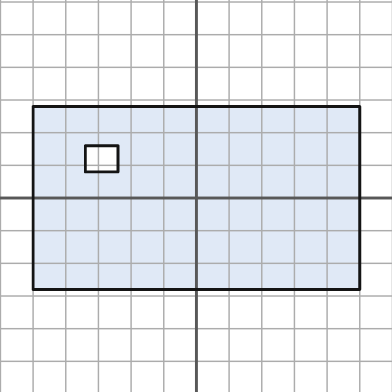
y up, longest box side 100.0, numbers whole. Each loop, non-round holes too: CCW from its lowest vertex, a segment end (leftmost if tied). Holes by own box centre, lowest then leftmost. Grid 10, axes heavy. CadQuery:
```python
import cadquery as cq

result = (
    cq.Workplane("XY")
    .moveTo(-50.0, -28.0)
    .lineTo(50.0, -28.0)
    .lineTo(50.0, 28.0)
    .lineTo(-50.0, 28.0)
    .close()
    .moveTo(-34.0, 8.0)
    .lineTo(-24.0, 8.0)
    .lineTo(-24.0, 16.0)
    .lineTo(-34.0, 16.0)
    .close()
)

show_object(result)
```